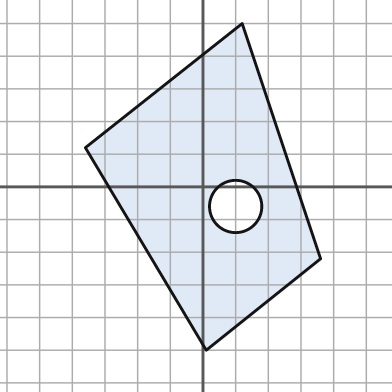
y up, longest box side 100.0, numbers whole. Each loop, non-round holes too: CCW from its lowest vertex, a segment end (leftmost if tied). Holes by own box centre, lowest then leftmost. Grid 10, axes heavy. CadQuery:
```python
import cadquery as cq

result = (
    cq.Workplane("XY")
    .moveTo(1.0, -50.0)
    .lineTo(36.0, -22.0)
    .lineTo(12.0, 50.0)
    .lineTo(-36.0, 12.0)
    .close()
    .moveTo(10.0, -6.0)
    .circle(8.0)
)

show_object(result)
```